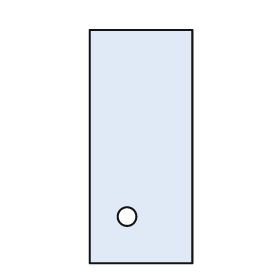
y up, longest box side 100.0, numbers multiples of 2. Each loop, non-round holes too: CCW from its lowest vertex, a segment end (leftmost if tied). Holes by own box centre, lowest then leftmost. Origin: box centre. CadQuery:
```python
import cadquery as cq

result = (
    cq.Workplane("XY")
    .moveTo(-22.0, -50.0)
    .lineTo(22.0, -50.0)
    .lineTo(22.0, 50.0)
    .lineTo(-22.0, 50.0)
    .close()
    .moveTo(-6.0, -30.0)
    .circle(4.0)
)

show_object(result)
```